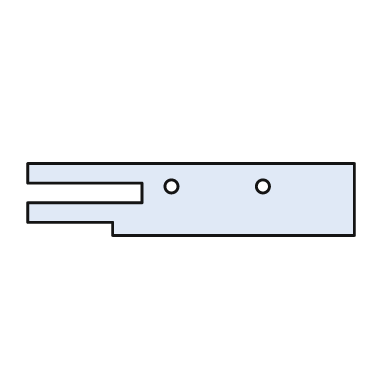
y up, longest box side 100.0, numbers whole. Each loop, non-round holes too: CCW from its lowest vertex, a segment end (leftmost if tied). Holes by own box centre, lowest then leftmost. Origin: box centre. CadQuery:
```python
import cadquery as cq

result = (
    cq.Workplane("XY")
    .moveTo(-24.0, -11.0)
    .lineTo(50.0, -11.0)
    .lineTo(50.0, 11.0)
    .lineTo(-50.0, 11.0)
    .lineTo(-50.0, 5.0)
    .lineTo(-15.0, 5.0)
    .lineTo(-15.0, -1.0)
    .lineTo(-50.0, -1.0)
    .lineTo(-50.0, -7.0)
    .lineTo(-24.0, -7.0)
    .close()
    .moveTo(-6.0, 4.0)
    .circle(2.0)
    .moveTo(22.0, 4.0)
    .circle(2.0)
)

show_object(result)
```